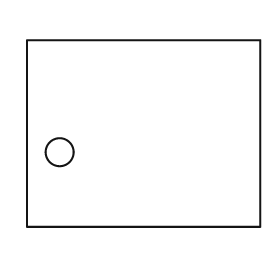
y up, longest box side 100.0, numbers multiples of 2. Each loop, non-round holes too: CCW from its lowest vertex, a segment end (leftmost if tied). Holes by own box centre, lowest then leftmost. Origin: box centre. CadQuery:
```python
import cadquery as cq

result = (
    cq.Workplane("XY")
    .moveTo(-50.0, -40.0)
    .lineTo(50.0, -40.0)
    .lineTo(50.0, 40.0)
    .lineTo(-50.0, 40.0)
    .close()
    .moveTo(-36.0, -8.0)
    .circle(6.0)
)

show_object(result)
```